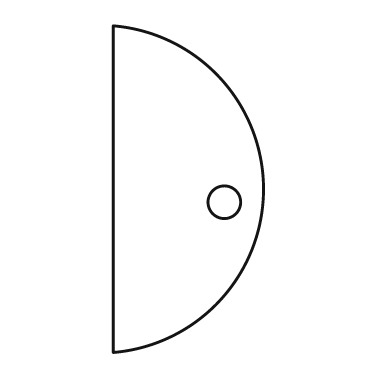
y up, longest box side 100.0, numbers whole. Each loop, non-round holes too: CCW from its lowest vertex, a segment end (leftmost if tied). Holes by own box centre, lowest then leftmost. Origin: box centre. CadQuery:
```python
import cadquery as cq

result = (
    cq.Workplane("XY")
    .moveTo(-23.0, -50.0)
    .threePointArc((23.0, 0.0), (-23.0, 50.0))
    .close()
    .moveTo(11.0, -4.0)
    .circle(5.0)
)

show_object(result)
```